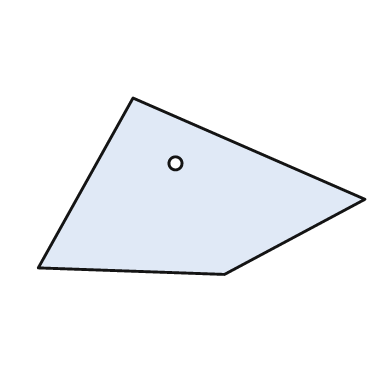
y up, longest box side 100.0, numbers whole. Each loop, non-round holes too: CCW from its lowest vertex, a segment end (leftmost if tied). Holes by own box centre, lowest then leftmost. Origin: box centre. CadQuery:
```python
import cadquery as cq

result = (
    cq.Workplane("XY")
    .moveTo(7.0, -27.0)
    .lineTo(50.0, -4.0)
    .lineTo(-21.0, 27.0)
    .lineTo(-50.0, -25.0)
    .close()
    .moveTo(-8.0, 7.0)
    .circle(2.0)
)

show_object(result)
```